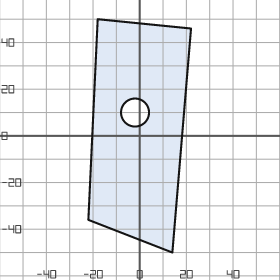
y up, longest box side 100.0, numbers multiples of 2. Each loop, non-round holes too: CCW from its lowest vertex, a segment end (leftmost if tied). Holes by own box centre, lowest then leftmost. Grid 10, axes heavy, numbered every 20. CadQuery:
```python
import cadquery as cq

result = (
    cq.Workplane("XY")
    .moveTo(14.0, -50.0)
    .lineTo(22.0, 46.0)
    .lineTo(-18.0, 50.0)
    .lineTo(-22.0, -36.0)
    .close()
    .moveTo(-2.0, 10.0)
    .circle(6.0)
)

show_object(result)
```